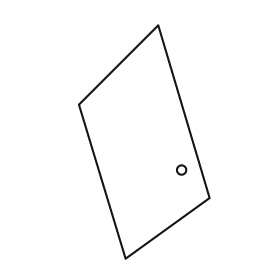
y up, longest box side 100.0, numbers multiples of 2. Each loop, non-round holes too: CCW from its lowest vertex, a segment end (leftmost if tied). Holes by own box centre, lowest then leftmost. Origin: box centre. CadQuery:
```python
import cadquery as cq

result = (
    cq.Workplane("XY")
    .moveTo(-8.0, -50.0)
    .lineTo(28.0, -24.0)
    .lineTo(6.0, 50.0)
    .lineTo(-28.0, 16.0)
    .close()
    .moveTo(16.0, -12.0)
    .circle(2.0)
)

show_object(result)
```